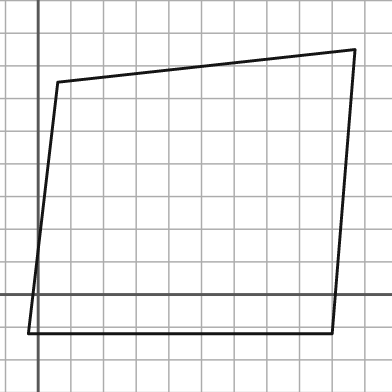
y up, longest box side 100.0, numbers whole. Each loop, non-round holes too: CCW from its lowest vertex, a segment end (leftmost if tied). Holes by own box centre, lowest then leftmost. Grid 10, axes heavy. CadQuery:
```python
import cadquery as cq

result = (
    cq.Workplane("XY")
    .moveTo(-3.0, -12.0)
    .lineTo(90.0, -12.0)
    .lineTo(97.0, 75.0)
    .lineTo(6.0, 65.0)
    .close()
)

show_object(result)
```